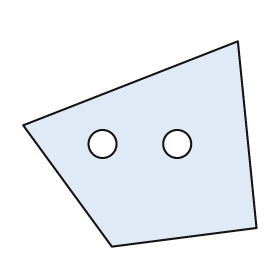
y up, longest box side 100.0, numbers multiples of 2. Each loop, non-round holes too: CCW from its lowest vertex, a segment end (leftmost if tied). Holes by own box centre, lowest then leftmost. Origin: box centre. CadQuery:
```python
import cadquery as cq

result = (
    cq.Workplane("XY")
    .moveTo(-12.0, -44.0)
    .lineTo(50.0, -36.0)
    .lineTo(42.0, 44.0)
    .lineTo(-50.0, 8.0)
    .close()
    .moveTo(-16.0, 0.0)
    .circle(6.0)
    .moveTo(16.0, 0.0)
    .circle(6.0)
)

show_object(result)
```